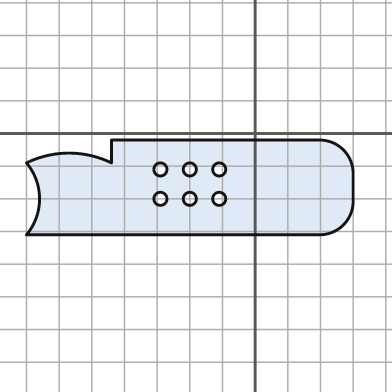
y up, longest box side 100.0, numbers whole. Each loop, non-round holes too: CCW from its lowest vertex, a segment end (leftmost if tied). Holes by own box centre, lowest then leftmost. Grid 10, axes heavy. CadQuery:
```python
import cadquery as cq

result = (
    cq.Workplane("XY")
    .moveTo(-70.0, -31.0)
    .lineTo(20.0, -31.0)
    .threePointArc((27.0, -28.0), (30.0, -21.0))
    .lineTo(30.0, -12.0)
    .threePointArc((27.0, -5.0), (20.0, -2.0))
    .lineTo(-44.0, -2.0)
    .lineTo(-44.0, -9.0)
    .threePointArc((-57.0, -6.0), (-70.0, -9.0))
    .threePointArc((-66.0, -20.0), (-70.0, -31.0))
    .close()
    .moveTo(-29.0, -20.0)
    .circle(2.0)
    .moveTo(-20.0, -20.0)
    .circle(2.0)
    .moveTo(-11.0, -20.0)
    .circle(2.0)
    .moveTo(-29.0, -11.0)
    .circle(2.0)
    .moveTo(-20.0, -11.0)
    .circle(2.0)
    .moveTo(-11.0, -11.0)
    .circle(2.0)
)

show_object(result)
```